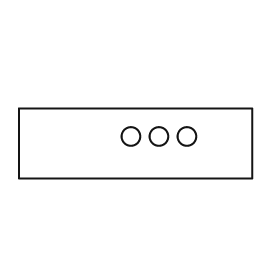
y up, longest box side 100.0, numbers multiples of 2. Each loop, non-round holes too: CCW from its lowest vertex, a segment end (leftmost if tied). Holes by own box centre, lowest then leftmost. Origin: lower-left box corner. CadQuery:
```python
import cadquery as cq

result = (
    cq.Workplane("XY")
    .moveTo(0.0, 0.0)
    .lineTo(100.0, 0.0)
    .lineTo(100.0, 30.0)
    .lineTo(0.0, 30.0)
    .close()
    .moveTo(48.0, 18.0)
    .circle(4.0)
    .moveTo(60.0, 18.0)
    .circle(4.0)
    .moveTo(72.0, 18.0)
    .circle(4.0)
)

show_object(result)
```